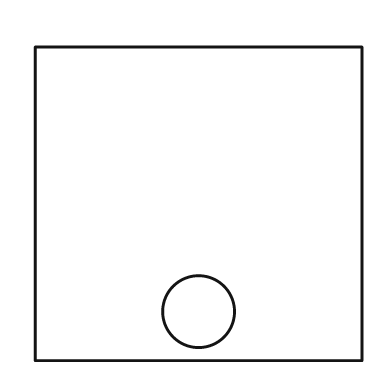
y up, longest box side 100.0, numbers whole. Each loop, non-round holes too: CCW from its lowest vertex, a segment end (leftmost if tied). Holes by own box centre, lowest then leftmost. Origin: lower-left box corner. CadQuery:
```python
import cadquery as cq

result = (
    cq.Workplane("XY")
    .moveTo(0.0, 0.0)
    .lineTo(100.0, 0.0)
    .lineTo(100.0, 96.0)
    .lineTo(0.0, 96.0)
    .close()
    .moveTo(50.0, 15.0)
    .circle(11.0)
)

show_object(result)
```